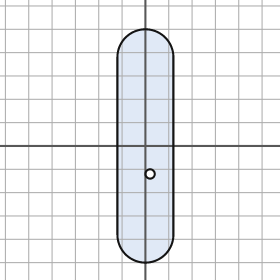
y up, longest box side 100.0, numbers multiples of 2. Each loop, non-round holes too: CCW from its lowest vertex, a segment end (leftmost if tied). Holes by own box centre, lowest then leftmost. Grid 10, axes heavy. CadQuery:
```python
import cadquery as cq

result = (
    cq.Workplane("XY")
    .moveTo(-12.0, -38.0)
    .threePointArc((0.0, -50.0), (12.0, -38.0))
    .lineTo(12.0, 38.0)
    .threePointArc((0.0, 50.0), (-12.0, 38.0))
    .close()
    .moveTo(2.0, -12.0)
    .circle(2.0)
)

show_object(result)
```